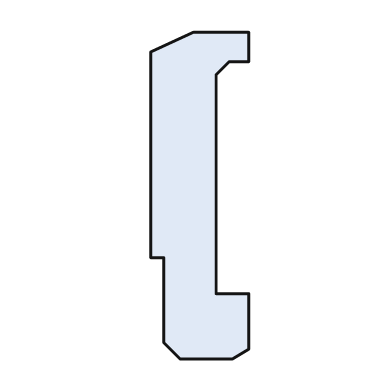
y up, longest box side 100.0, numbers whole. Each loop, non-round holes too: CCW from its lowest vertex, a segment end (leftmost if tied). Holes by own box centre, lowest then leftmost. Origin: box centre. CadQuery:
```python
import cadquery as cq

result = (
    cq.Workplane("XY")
    .moveTo(-6.0, -50.0)
    .lineTo(10.0, -50.0)
    .lineTo(15.0, -47.0)
    .lineTo(15.0, -30.0)
    .lineTo(5.0, -30.0)
    .lineTo(5.0, 37.0)
    .lineTo(9.0, 41.0)
    .lineTo(15.0, 41.0)
    .lineTo(15.0, 50.0)
    .lineTo(-2.0, 50.0)
    .lineTo(-15.0, 44.0)
    .lineTo(-15.0, -19.0)
    .lineTo(-11.0, -19.0)
    .lineTo(-11.0, -45.0)
    .close()
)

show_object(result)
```